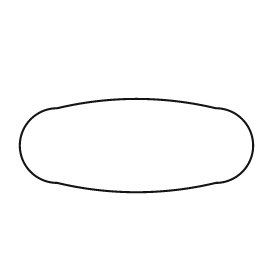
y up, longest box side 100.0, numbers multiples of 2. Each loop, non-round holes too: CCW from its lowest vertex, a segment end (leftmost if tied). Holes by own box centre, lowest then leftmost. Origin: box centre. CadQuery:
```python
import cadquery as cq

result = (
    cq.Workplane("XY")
    .moveTo(-34.0, -16.0)
    .threePointArc((0.0, -20.0), (34.0, -16.0))
    .threePointArc((50.0, 0.0), (34.0, 16.0))
    .threePointArc((0.0, 20.0), (-34.0, 16.0))
    .threePointArc((-50.0, 0.0), (-34.0, -16.0))
    .close()
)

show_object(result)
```